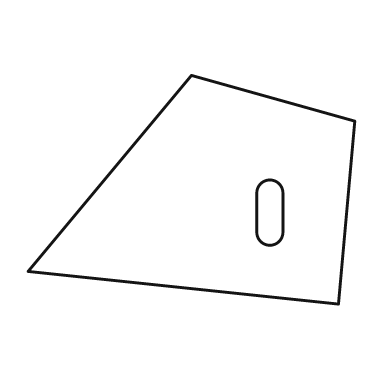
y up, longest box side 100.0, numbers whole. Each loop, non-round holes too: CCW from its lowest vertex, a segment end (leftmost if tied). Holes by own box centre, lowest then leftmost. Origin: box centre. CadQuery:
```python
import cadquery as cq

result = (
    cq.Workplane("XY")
    .moveTo(45.0, -35.0)
    .lineTo(50.0, 21.0)
    .lineTo(0.0, 35.0)
    .lineTo(-50.0, -25.0)
    .close()
    .moveTo(20.0, -13.0)
    .threePointArc((24.0, -17.0), (28.0, -13.0))
    .lineTo(28.0, -1.0)
    .threePointArc((24.0, 3.0), (20.0, -1.0))
    .close()
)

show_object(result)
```